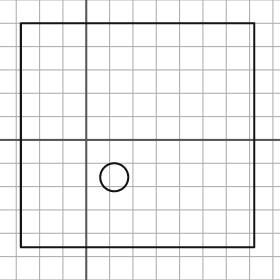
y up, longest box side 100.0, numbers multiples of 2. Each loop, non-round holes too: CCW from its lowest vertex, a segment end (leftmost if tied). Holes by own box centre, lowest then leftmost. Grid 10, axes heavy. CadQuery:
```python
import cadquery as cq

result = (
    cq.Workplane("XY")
    .moveTo(-28.0, -46.0)
    .lineTo(72.0, -46.0)
    .lineTo(72.0, 50.0)
    .lineTo(-28.0, 50.0)
    .close()
    .moveTo(12.0, -16.0)
    .circle(6.0)
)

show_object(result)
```